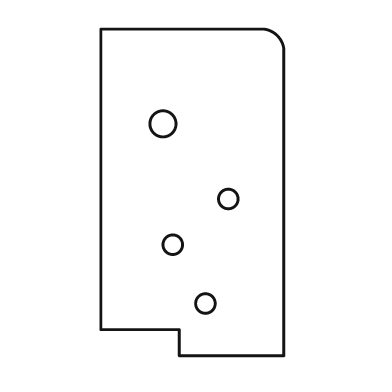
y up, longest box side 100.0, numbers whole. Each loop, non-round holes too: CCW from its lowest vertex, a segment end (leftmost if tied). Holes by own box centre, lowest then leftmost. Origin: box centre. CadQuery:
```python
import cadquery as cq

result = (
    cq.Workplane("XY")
    .moveTo(-4.0, -50.0)
    .lineTo(28.0, -50.0)
    .lineTo(28.0, 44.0)
    .threePointArc((26.0, 48.0), (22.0, 50.0))
    .lineTo(-28.0, 50.0)
    .lineTo(-28.0, -42.0)
    .lineTo(-4.0, -42.0)
    .close()
    .moveTo(4.0, -34.0)
    .circle(3.0)
    .moveTo(-6.0, -16.0)
    .circle(3.0)
    .moveTo(11.0, -2.0)
    .circle(3.0)
    .moveTo(-9.0, 21.0)
    .circle(4.0)
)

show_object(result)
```